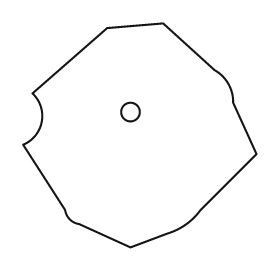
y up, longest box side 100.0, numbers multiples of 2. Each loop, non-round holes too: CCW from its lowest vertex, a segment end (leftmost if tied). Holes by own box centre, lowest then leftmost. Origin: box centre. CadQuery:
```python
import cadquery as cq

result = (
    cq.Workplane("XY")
    .moveTo(-4.0, -48.0)
    .lineTo(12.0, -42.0)
    .threePointArc((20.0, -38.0), (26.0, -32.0))
    .lineTo(50.0, -8.0)
    .lineTo(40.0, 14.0)
    .threePointArc((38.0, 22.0), (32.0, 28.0))
    .lineTo(10.0, 48.0)
    .lineTo(-14.0, 46.0)
    .lineTo(-46.0, 18.0)
    .threePointArc((-42.0, 6.0), (-50.0, -4.0))
    .lineTo(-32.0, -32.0)
    .threePointArc((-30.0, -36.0), (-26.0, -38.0))
    .close()
    .moveTo(-4.0, 10.0)
    .circle(4.0)
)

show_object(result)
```